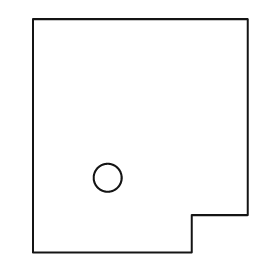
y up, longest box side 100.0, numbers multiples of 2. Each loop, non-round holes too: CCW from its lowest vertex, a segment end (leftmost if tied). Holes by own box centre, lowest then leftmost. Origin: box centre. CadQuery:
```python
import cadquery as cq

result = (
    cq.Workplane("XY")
    .moveTo(-46.0, -50.0)
    .lineTo(22.0, -50.0)
    .lineTo(22.0, -34.0)
    .lineTo(46.0, -34.0)
    .lineTo(46.0, 50.0)
    .lineTo(-46.0, 50.0)
    .close()
    .moveTo(-14.0, -18.0)
    .circle(6.0)
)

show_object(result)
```